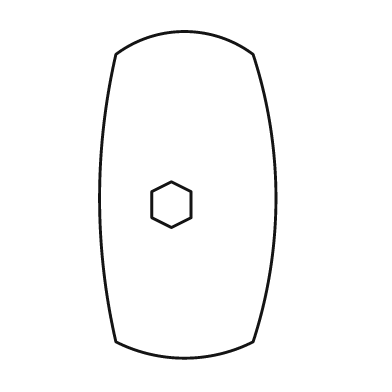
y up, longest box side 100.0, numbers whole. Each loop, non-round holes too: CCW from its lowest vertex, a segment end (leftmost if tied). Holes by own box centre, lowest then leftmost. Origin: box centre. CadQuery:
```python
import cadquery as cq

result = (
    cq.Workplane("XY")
    .moveTo(-22.0, -45.0)
    .threePointArc((-1.0, -50.0), (20.0, -45.0))
    .threePointArc((27.0, -1.0), (20.0, 43.0))
    .threePointArc((-1.0, 50.0), (-22.0, 43.0))
    .threePointArc((-27.0, -1.0), (-22.0, -45.0))
    .close()
    .moveTo(-5.0, -10.0)
    .lineTo(1.0, -7.0)
    .lineTo(1.0, 1.0)
    .lineTo(-5.0, 4.0)
    .lineTo(-11.0, 1.0)
    .lineTo(-11.0, -7.0)
    .close()
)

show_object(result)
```